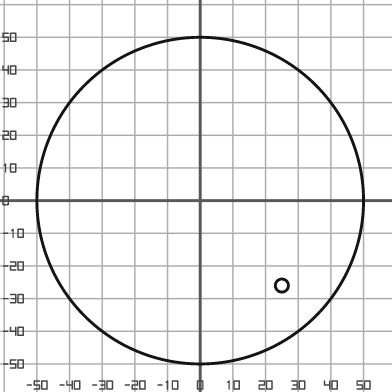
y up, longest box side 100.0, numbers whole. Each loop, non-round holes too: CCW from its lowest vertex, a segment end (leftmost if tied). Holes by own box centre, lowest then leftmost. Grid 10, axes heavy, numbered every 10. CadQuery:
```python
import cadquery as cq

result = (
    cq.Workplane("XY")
    .moveTo(0.0, 0.0)
    .circle(50.0)
    .moveTo(25.0, -26.0)
    .circle(2.0)
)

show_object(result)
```